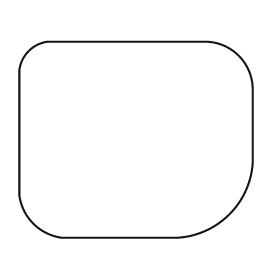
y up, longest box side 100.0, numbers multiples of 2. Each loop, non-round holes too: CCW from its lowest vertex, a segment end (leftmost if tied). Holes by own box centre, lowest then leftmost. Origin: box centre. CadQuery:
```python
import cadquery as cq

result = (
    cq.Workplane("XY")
    .moveTo(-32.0, -42.0)
    .lineTo(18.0, -42.0)
    .threePointArc((40.0, -32.0), (50.0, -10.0))
    .lineTo(50.0, 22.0)
    .threePointArc((44.0, 36.0), (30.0, 42.0))
    .lineTo(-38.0, 42.0)
    .threePointArc((-46.0, 38.0), (-50.0, 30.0))
    .lineTo(-50.0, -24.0)
    .threePointArc((-44.0, -36.0), (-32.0, -42.0))
    .close()
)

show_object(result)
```